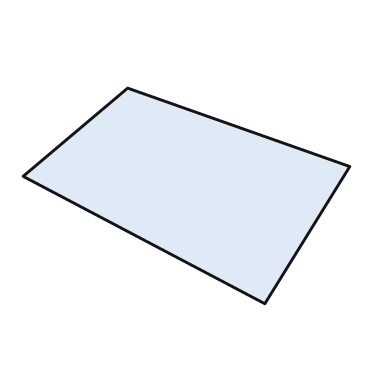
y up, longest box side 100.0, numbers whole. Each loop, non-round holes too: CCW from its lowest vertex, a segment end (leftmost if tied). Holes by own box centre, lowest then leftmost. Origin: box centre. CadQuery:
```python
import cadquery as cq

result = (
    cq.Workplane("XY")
    .moveTo(24.0, -33.0)
    .lineTo(50.0, 9.0)
    .lineTo(-18.0, 33.0)
    .lineTo(-50.0, 6.0)
    .close()
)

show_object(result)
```